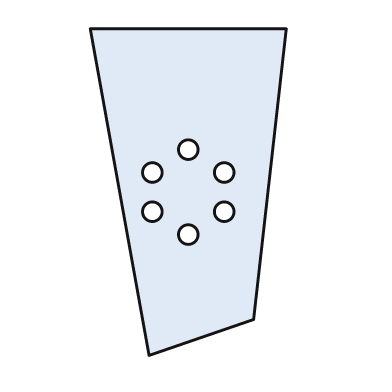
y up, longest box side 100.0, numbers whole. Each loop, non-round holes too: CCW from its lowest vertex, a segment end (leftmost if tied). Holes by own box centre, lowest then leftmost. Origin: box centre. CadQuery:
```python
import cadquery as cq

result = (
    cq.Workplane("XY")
    .moveTo(-12.0, -50.0)
    .lineTo(20.0, -39.0)
    .lineTo(30.0, 50.0)
    .lineTo(-30.0, 50.0)
    .close()
    .moveTo(0.0, -13.0)
    .circle(3.0)
    .moveTo(-11.0, -6.0)
    .circle(3.0)
    .moveTo(11.0, -6.0)
    .circle(3.0)
    .moveTo(-11.0, 6.0)
    .circle(3.0)
    .moveTo(11.0, 6.0)
    .circle(3.0)
    .moveTo(0.0, 13.0)
    .circle(3.0)
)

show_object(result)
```